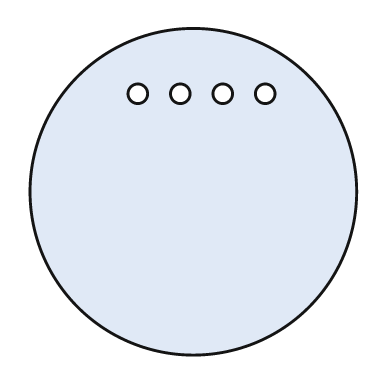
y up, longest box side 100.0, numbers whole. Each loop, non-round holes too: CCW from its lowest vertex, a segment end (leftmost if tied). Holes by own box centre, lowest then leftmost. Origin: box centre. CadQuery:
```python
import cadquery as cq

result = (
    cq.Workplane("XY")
    .moveTo(0.0, 0.0)
    .circle(50.0)
    .moveTo(-17.0, 30.0)
    .circle(3.0)
    .moveTo(-4.0, 30.0)
    .circle(3.0)
    .moveTo(9.0, 30.0)
    .circle(3.0)
    .moveTo(22.0, 30.0)
    .circle(3.0)
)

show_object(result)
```